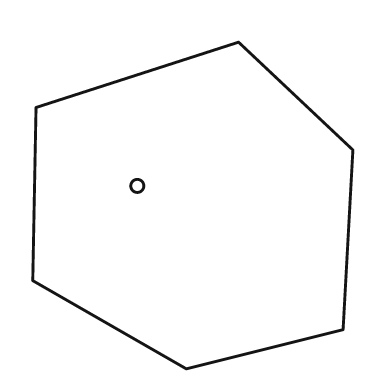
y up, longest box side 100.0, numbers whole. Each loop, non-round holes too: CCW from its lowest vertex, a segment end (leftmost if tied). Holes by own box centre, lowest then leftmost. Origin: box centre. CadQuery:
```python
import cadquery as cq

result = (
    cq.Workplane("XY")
    .moveTo(-2.0, -50.0)
    .lineTo(46.0, -38.0)
    .lineTo(49.0, 17.0)
    .lineTo(14.0, 50.0)
    .lineTo(-48.0, 30.0)
    .lineTo(-49.0, -23.0)
    .close()
    .moveTo(-17.0, 6.0)
    .circle(2.0)
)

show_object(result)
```